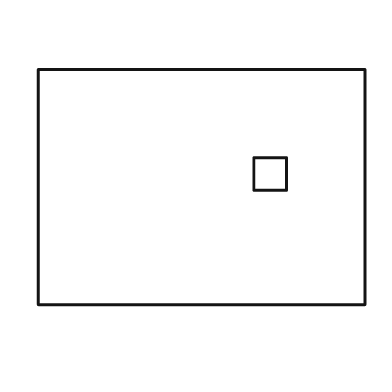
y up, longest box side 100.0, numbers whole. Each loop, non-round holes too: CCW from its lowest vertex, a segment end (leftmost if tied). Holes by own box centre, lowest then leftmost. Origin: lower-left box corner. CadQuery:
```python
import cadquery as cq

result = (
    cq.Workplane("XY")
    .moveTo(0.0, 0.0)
    .lineTo(100.0, 0.0)
    .lineTo(100.0, 72.0)
    .lineTo(0.0, 72.0)
    .close()
    .moveTo(66.0, 35.0)
    .lineTo(76.0, 35.0)
    .lineTo(76.0, 45.0)
    .lineTo(66.0, 45.0)
    .close()
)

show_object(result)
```